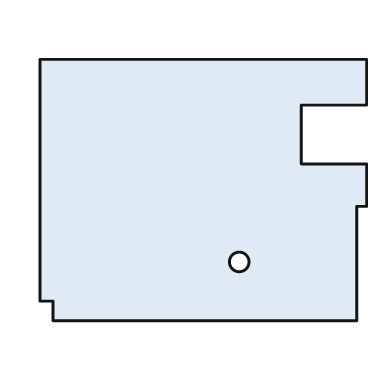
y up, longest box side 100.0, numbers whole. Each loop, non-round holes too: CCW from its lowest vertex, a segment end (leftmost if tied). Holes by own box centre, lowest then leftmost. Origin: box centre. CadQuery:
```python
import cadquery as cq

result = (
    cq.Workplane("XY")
    .moveTo(-46.0, -40.0)
    .lineTo(47.0, -40.0)
    .lineTo(47.0, -5.0)
    .lineTo(50.0, -5.0)
    .lineTo(50.0, 8.0)
    .lineTo(30.0, 8.0)
    .lineTo(30.0, 26.0)
    .lineTo(50.0, 26.0)
    .lineTo(50.0, 40.0)
    .lineTo(-50.0, 40.0)
    .lineTo(-50.0, -34.0)
    .lineTo(-46.0, -34.0)
    .close()
    .moveTo(11.0, -22.0)
    .circle(3.0)
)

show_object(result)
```